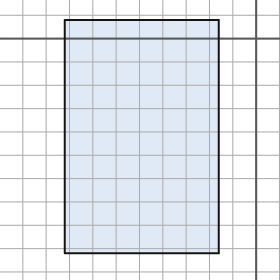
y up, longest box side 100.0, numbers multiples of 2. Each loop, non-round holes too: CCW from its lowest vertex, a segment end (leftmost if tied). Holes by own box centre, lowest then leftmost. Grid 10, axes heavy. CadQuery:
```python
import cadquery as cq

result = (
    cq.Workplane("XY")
    .moveTo(-82.0, -92.0)
    .lineTo(-16.0, -92.0)
    .lineTo(-16.0, 8.0)
    .lineTo(-82.0, 8.0)
    .close()
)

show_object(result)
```